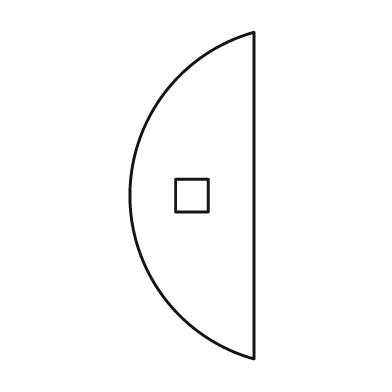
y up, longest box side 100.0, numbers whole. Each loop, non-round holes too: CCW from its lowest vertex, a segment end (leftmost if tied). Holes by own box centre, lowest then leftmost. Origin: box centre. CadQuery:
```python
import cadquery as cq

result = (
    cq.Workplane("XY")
    .moveTo(19.0, -50.0)
    .lineTo(19.0, 50.0)
    .threePointArc((-19.0, 0.0), (19.0, -50.0))
    .close()
    .moveTo(-5.0, -5.0)
    .lineTo(5.0, -5.0)
    .lineTo(5.0, 5.0)
    .lineTo(-5.0, 5.0)
    .close()
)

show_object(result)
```